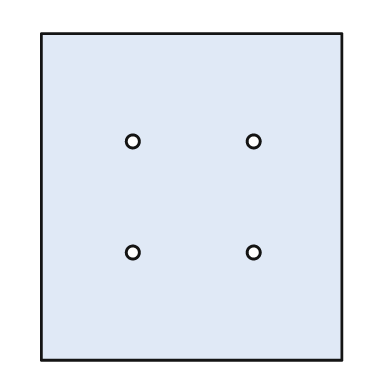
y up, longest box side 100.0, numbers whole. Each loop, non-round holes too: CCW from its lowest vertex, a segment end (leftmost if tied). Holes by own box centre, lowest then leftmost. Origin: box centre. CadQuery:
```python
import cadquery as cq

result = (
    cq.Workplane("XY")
    .moveTo(-46.0, -50.0)
    .lineTo(46.0, -50.0)
    .lineTo(46.0, 50.0)
    .lineTo(-46.0, 50.0)
    .close()
    .moveTo(-18.0, -17.0)
    .circle(2.0)
    .moveTo(19.0, -17.0)
    .circle(2.0)
    .moveTo(-18.0, 17.0)
    .circle(2.0)
    .moveTo(19.0, 17.0)
    .circle(2.0)
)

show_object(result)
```